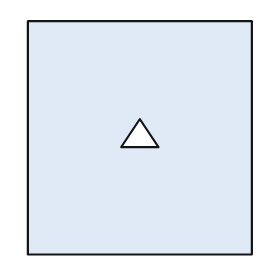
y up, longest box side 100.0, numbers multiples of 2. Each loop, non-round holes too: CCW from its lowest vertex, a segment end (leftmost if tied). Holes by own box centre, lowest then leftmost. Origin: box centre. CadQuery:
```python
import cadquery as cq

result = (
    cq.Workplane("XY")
    .moveTo(-48.0, -50.0)
    .lineTo(48.0, -50.0)
    .lineTo(48.0, 50.0)
    .lineTo(-48.0, 50.0)
    .close()
    .moveTo(-8.0, -4.0)
    .lineTo(8.0, -4.0)
    .lineTo(0.0, 8.0)
    .close()
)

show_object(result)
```